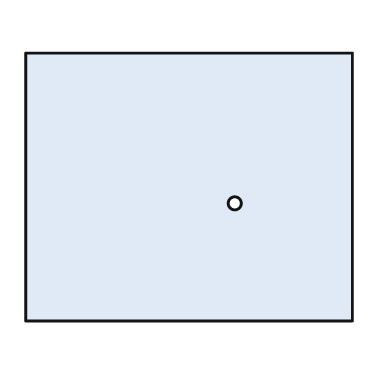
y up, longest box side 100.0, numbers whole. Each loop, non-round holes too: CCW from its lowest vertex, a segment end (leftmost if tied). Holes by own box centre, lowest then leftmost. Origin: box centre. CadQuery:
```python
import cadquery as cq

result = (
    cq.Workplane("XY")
    .moveTo(-50.0, -41.0)
    .lineTo(50.0, -41.0)
    .lineTo(50.0, 41.0)
    .lineTo(-50.0, 41.0)
    .close()
    .moveTo(14.0, -5.0)
    .circle(2.0)
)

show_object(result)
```